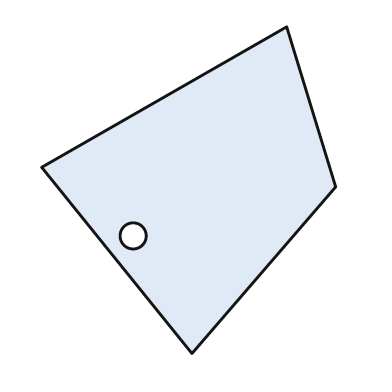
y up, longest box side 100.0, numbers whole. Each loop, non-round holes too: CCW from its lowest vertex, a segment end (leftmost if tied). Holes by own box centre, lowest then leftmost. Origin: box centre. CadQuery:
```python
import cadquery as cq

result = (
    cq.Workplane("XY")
    .moveTo(1.0, -50.0)
    .lineTo(45.0, 1.0)
    .lineTo(30.0, 50.0)
    .lineTo(-45.0, 7.0)
    .close()
    .moveTo(-17.0, -14.0)
    .circle(4.0)
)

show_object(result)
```